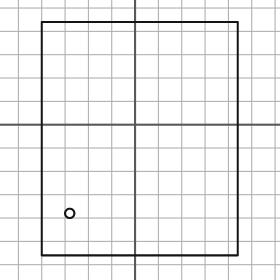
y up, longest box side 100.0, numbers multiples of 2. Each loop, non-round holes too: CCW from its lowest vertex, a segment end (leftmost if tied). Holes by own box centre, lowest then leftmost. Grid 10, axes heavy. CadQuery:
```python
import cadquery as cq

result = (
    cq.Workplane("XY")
    .moveTo(-40.0, -56.0)
    .lineTo(44.0, -56.0)
    .lineTo(44.0, 44.0)
    .lineTo(-40.0, 44.0)
    .close()
    .moveTo(-28.0, -38.0)
    .circle(2.0)
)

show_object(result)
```